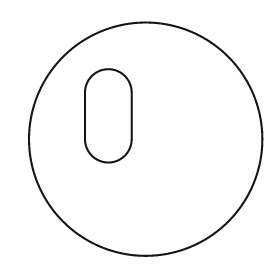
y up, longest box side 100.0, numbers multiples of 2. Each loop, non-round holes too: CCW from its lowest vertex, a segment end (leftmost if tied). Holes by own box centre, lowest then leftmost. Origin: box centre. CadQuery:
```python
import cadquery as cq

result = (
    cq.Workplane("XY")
    .moveTo(0.0, 0.0)
    .circle(50.0)
    .moveTo(-26.0, 0.0)
    .threePointArc((-16.0, -10.0), (-6.0, 0.0))
    .lineTo(-6.0, 20.0)
    .threePointArc((-16.0, 30.0), (-26.0, 20.0))
    .close()
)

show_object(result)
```